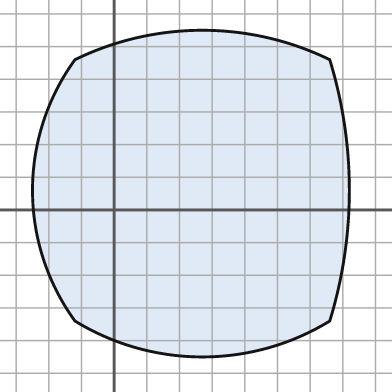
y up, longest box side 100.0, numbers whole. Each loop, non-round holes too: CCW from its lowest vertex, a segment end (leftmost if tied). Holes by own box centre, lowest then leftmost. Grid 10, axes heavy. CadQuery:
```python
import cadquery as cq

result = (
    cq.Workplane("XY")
    .moveTo(-12.0, -34.0)
    .threePointArc((27.0, -45.0), (66.0, -34.0))
    .threePointArc((72.0, 6.0), (66.0, 46.0))
    .threePointArc((27.0, 55.0), (-12.0, 46.0))
    .threePointArc((-25.0, 6.0), (-12.0, -34.0))
    .close()
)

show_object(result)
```